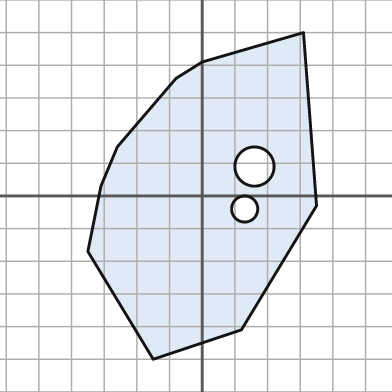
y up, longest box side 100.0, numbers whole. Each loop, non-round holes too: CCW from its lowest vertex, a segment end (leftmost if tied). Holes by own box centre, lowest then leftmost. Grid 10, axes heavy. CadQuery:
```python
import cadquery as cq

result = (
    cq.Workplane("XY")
    .moveTo(-15.0, -50.0)
    .lineTo(12.0, -41.0)
    .lineTo(35.0, -3.0)
    .lineTo(31.0, 50.0)
    .lineTo(0.0, 41.0)
    .lineTo(-8.0, 36.0)
    .lineTo(-26.0, 15.0)
    .lineTo(-31.0, 3.0)
    .lineTo(-35.0, -17.0)
    .close()
    .moveTo(13.0, -4.0)
    .circle(4.0)
    .moveTo(16.0, 9.0)
    .circle(6.0)
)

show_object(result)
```